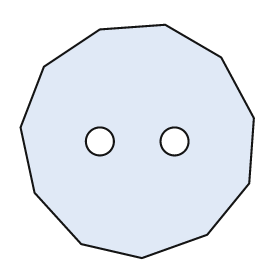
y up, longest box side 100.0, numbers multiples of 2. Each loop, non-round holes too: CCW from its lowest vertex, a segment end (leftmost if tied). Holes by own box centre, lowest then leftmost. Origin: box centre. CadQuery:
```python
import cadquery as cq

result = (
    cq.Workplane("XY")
    .moveTo(2.0, -50.0)
    .lineTo(30.0, -40.0)
    .lineTo(48.0, -18.0)
    .lineTo(50.0, 10.0)
    .lineTo(36.0, 36.0)
    .lineTo(12.0, 50.0)
    .lineTo(-16.0, 48.0)
    .lineTo(-40.0, 32.0)
    .lineTo(-50.0, 6.0)
    .lineTo(-44.0, -22.0)
    .lineTo(-24.0, -44.0)
    .close()
    .moveTo(-16.0, 0.0)
    .circle(6.0)
    .moveTo(16.0, 0.0)
    .circle(6.0)
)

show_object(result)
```